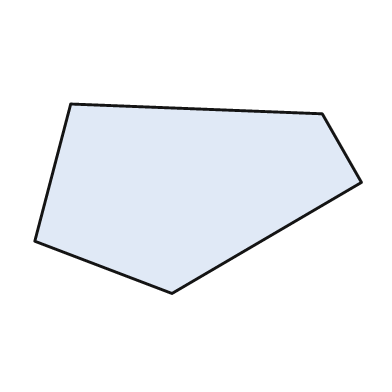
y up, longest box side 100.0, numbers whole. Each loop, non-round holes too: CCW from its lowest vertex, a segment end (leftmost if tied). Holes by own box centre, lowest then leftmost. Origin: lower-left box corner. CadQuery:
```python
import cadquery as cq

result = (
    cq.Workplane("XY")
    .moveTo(42.0, 0.0)
    .lineTo(100.0, 34.0)
    .lineTo(88.0, 55.0)
    .lineTo(11.0, 58.0)
    .lineTo(0.0, 16.0)
    .close()
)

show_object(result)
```